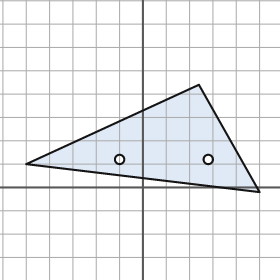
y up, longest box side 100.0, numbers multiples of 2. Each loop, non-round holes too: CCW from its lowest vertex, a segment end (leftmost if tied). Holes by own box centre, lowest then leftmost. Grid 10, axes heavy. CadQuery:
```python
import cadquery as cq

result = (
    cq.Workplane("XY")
    .moveTo(50.0, -2.0)
    .lineTo(24.0, 44.0)
    .lineTo(-50.0, 10.0)
    .close()
    .moveTo(-10.0, 12.0)
    .circle(2.0)
    .moveTo(28.0, 12.0)
    .circle(2.0)
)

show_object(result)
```